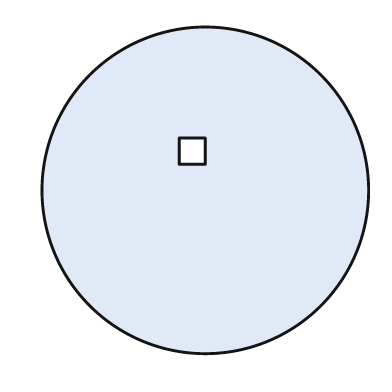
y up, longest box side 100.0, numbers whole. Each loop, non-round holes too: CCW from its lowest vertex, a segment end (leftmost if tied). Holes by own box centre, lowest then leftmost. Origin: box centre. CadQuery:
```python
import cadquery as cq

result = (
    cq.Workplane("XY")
    .moveTo(0.0, 0.0)
    .circle(50.0)
    .moveTo(-8.0, 8.0)
    .lineTo(0.0, 8.0)
    .lineTo(0.0, 16.0)
    .lineTo(-8.0, 16.0)
    .close()
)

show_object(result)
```